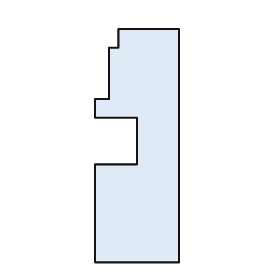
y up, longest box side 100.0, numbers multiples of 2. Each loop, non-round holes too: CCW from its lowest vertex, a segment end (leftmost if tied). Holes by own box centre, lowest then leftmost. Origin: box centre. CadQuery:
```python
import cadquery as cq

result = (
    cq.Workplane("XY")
    .moveTo(-18.0, -50.0)
    .lineTo(18.0, -50.0)
    .lineTo(18.0, 50.0)
    .lineTo(-8.0, 50.0)
    .lineTo(-8.0, 42.0)
    .lineTo(-12.0, 42.0)
    .lineTo(-12.0, 20.0)
    .lineTo(-18.0, 20.0)
    .lineTo(-18.0, 12.0)
    .lineTo(0.0, 12.0)
    .lineTo(0.0, -8.0)
    .lineTo(-18.0, -8.0)
    .close()
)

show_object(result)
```